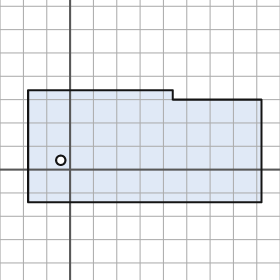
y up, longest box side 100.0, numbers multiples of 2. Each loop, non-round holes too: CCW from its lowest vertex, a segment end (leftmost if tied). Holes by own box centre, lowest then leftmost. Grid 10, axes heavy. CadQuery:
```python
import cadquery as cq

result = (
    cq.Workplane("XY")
    .moveTo(-18.0, -14.0)
    .lineTo(82.0, -14.0)
    .lineTo(82.0, 30.0)
    .lineTo(44.0, 30.0)
    .lineTo(44.0, 34.0)
    .lineTo(-18.0, 34.0)
    .close()
    .moveTo(-4.0, 4.0)
    .circle(2.0)
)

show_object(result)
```